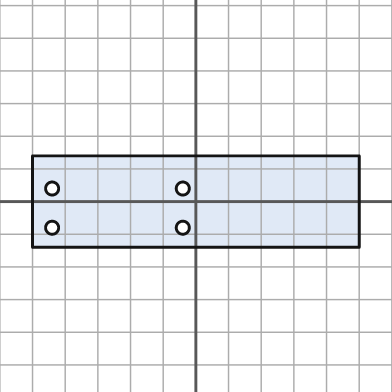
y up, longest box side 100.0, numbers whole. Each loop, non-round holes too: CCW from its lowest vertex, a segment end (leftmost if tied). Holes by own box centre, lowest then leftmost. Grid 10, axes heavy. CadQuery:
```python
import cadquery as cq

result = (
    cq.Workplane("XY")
    .moveTo(-50.0, -14.0)
    .lineTo(50.0, -14.0)
    .lineTo(50.0, 14.0)
    .lineTo(-50.0, 14.0)
    .close()
    .moveTo(-44.0, -8.0)
    .circle(2.0)
    .moveTo(-4.0, -8.0)
    .circle(2.0)
    .moveTo(-44.0, 4.0)
    .circle(2.0)
    .moveTo(-4.0, 4.0)
    .circle(2.0)
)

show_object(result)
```